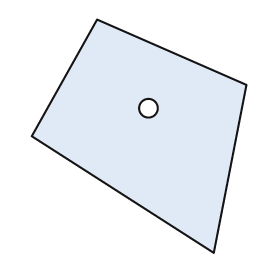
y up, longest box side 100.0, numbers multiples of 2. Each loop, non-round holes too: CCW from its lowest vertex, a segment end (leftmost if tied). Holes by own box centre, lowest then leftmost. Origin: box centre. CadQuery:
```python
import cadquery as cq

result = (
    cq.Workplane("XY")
    .moveTo(32.0, -50.0)
    .lineTo(46.0, 22.0)
    .lineTo(-18.0, 50.0)
    .lineTo(-46.0, 0.0)
    .close()
    .moveTo(4.0, 12.0)
    .circle(4.0)
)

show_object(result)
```